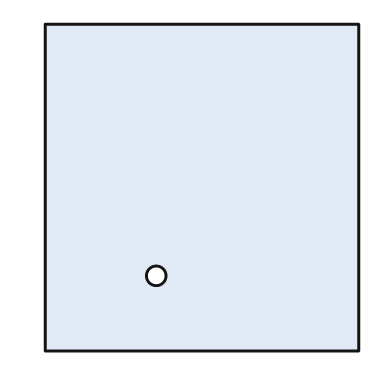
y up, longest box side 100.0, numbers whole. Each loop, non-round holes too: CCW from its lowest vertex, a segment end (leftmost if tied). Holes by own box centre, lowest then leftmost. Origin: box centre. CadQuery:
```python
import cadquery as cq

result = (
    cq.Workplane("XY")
    .moveTo(-48.0, -50.0)
    .lineTo(48.0, -50.0)
    .lineTo(48.0, 50.0)
    .lineTo(-48.0, 50.0)
    .close()
    .moveTo(-14.0, -27.0)
    .circle(3.0)
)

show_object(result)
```